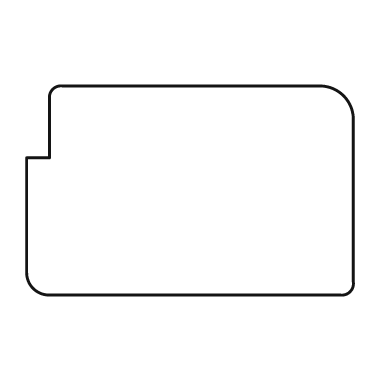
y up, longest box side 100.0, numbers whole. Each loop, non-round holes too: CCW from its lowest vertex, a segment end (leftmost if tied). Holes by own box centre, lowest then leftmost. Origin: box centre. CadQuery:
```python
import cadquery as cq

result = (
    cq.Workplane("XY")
    .moveTo(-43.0, -32.0)
    .lineTo(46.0, -32.0)
    .threePointArc((49.0, -31.0), (50.0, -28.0))
    .lineTo(50.0, 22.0)
    .threePointArc((47.0, 29.0), (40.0, 32.0))
    .lineTo(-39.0, 32.0)
    .threePointArc((-42.0, 31.0), (-43.0, 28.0))
    .lineTo(-43.0, 10.0)
    .lineTo(-50.0, 10.0)
    .lineTo(-50.0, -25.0)
    .threePointArc((-48.0, -30.0), (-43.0, -32.0))
    .close()
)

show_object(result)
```